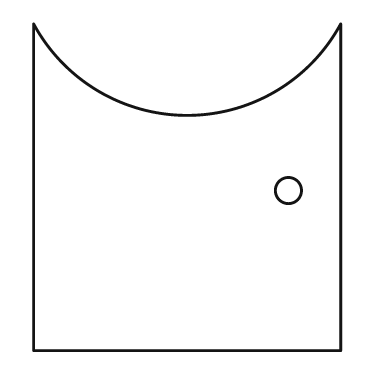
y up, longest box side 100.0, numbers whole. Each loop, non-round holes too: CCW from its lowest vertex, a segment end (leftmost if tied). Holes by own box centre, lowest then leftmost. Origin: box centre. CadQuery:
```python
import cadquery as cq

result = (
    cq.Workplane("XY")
    .moveTo(-47.0, -50.0)
    .lineTo(47.0, -50.0)
    .lineTo(47.0, 50.0)
    .threePointArc((0.0, 22.0), (-47.0, 50.0))
    .close()
    .moveTo(31.0, -1.0)
    .circle(4.0)
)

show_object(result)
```